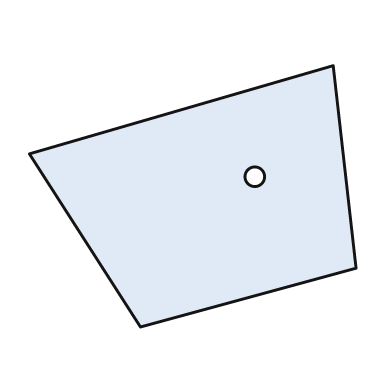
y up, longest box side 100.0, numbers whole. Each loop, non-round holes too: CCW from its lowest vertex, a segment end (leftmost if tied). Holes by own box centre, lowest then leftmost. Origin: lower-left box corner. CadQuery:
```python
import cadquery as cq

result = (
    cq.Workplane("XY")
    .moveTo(34.0, 0.0)
    .lineTo(100.0, 18.0)
    .lineTo(93.0, 80.0)
    .lineTo(0.0, 53.0)
    .close()
    .moveTo(69.0, 46.0)
    .circle(3.0)
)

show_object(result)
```